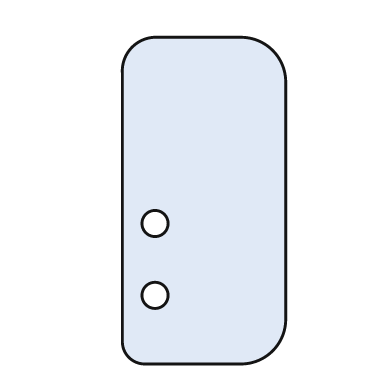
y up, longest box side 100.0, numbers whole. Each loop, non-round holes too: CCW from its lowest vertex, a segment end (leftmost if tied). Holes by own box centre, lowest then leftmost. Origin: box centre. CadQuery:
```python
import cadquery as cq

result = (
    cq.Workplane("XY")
    .moveTo(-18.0, -50.0)
    .lineTo(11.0, -50.0)
    .threePointArc((21.0, -46.0), (25.0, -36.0))
    .lineTo(25.0, 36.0)
    .threePointArc((21.0, 46.0), (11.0, 50.0))
    .lineTo(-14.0, 50.0)
    .threePointArc((-22.0, 47.0), (-25.0, 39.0))
    .lineTo(-25.0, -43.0)
    .threePointArc((-23.0, -48.0), (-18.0, -50.0))
    .close()
    .moveTo(-15.0, -29.0)
    .circle(4.0)
    .moveTo(-15.0, -7.0)
    .circle(4.0)
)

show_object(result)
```